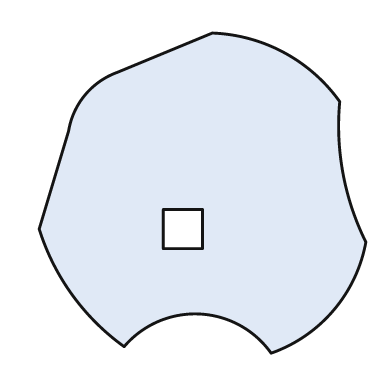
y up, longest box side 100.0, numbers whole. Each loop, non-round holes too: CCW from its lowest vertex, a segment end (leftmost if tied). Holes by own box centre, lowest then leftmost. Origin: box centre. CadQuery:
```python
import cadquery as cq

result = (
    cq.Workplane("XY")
    .moveTo(21.0, -49.0)
    .threePointArc((40.0, -36.0), (50.0, -15.0))
    .threePointArc((43.0, 6.0), (42.0, 28.0))
    .threePointArc((25.0, 43.0), (3.0, 49.0))
    .lineTo(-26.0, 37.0)
    .threePointArc((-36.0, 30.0), (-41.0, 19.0))
    .lineTo(-50.0, -11.0)
    .threePointArc((-40.0, -31.0), (-24.0, -47.0))
    .threePointArc((-1.0, -37.0), (21.0, -49.0))
    .close()
    .moveTo(-12.0, -17.0)
    .lineTo(0.0, -17.0)
    .lineTo(0.0, -5.0)
    .lineTo(-12.0, -5.0)
    .close()
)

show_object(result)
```